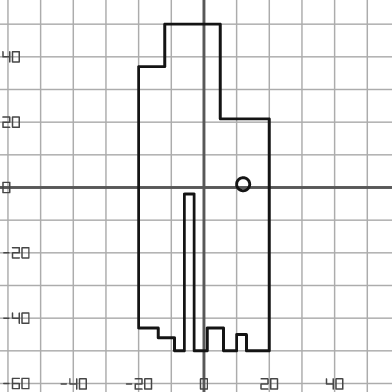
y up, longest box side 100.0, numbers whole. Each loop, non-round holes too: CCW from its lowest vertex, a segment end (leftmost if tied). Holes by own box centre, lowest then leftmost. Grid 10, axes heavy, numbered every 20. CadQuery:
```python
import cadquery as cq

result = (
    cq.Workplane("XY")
    .moveTo(-9.0, -50.0)
    .lineTo(-6.0, -50.0)
    .lineTo(-6.0, -2.0)
    .lineTo(-3.0, -2.0)
    .lineTo(-3.0, -50.0)
    .lineTo(1.0, -50.0)
    .lineTo(1.0, -43.0)
    .lineTo(6.0, -43.0)
    .lineTo(6.0, -50.0)
    .lineTo(10.0, -50.0)
    .lineTo(10.0, -45.0)
    .lineTo(13.0, -45.0)
    .lineTo(13.0, -50.0)
    .lineTo(20.0, -50.0)
    .lineTo(20.0, 21.0)
    .lineTo(5.0, 21.0)
    .lineTo(5.0, 50.0)
    .lineTo(-12.0, 50.0)
    .lineTo(-12.0, 37.0)
    .lineTo(-20.0, 37.0)
    .lineTo(-20.0, -43.0)
    .lineTo(-14.0, -43.0)
    .lineTo(-14.0, -46.0)
    .lineTo(-9.0, -46.0)
    .close()
    .moveTo(12.0, 1.0)
    .circle(2.0)
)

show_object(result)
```